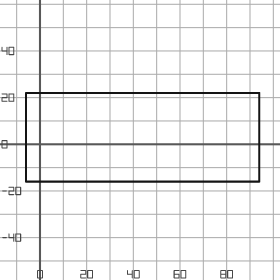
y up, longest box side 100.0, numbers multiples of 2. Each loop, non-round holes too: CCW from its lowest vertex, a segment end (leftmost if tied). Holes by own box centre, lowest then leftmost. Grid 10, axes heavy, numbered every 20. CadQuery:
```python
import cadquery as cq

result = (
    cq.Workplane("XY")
    .moveTo(-6.0, -16.0)
    .lineTo(94.0, -16.0)
    .lineTo(94.0, 22.0)
    .lineTo(-6.0, 22.0)
    .close()
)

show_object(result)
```